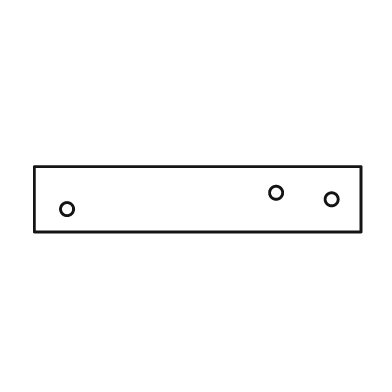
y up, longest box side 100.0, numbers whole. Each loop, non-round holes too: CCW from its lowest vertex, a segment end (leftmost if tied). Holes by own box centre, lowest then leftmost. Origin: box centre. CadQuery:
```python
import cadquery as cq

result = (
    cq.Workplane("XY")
    .moveTo(-50.0, -10.0)
    .lineTo(50.0, -10.0)
    .lineTo(50.0, 10.0)
    .lineTo(-50.0, 10.0)
    .close()
    .moveTo(-40.0, -3.0)
    .circle(2.0)
    .moveTo(41.0, 0.0)
    .circle(2.0)
    .moveTo(24.0, 2.0)
    .circle(2.0)
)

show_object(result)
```